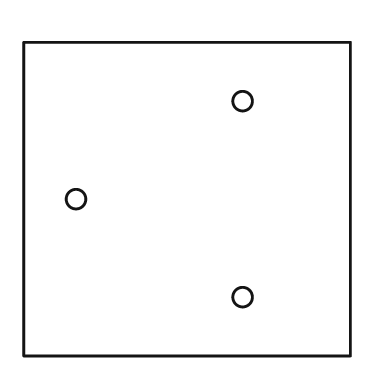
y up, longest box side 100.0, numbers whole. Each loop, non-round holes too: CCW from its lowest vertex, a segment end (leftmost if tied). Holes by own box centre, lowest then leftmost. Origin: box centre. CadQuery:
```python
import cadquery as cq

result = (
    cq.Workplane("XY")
    .moveTo(-50.0, -48.0)
    .lineTo(50.0, -48.0)
    .lineTo(50.0, 48.0)
    .lineTo(-50.0, 48.0)
    .close()
    .moveTo(17.0, -30.0)
    .circle(3.0)
    .moveTo(-34.0, 0.0)
    .circle(3.0)
    .moveTo(17.0, 30.0)
    .circle(3.0)
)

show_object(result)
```